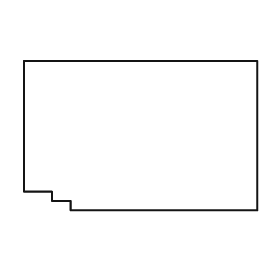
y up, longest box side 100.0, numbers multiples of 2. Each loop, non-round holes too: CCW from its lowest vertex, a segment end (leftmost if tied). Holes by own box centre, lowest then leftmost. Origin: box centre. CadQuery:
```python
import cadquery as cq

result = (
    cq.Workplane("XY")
    .moveTo(-30.0, -32.0)
    .lineTo(50.0, -32.0)
    .lineTo(50.0, 32.0)
    .lineTo(-50.0, 32.0)
    .lineTo(-50.0, -24.0)
    .lineTo(-38.0, -24.0)
    .lineTo(-38.0, -28.0)
    .lineTo(-30.0, -28.0)
    .close()
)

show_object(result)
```